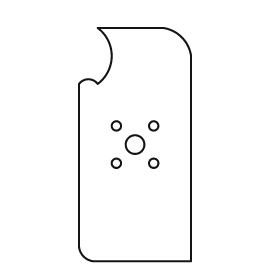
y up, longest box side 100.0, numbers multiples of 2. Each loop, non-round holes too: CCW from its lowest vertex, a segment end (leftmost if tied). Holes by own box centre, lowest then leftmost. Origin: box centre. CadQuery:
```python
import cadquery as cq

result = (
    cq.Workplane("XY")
    .moveTo(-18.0, -50.0)
    .lineTo(24.0, -50.0)
    .lineTo(24.0, 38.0)
    .threePointArc((20.0, 46.0), (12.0, 50.0))
    .lineTo(-16.0, 50.0)
    .threePointArc((-10.0, 38.0), (-16.0, 26.0))
    .threePointArc((-20.0, 28.0), (-24.0, 26.0))
    .lineTo(-24.0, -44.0)
    .threePointArc((-22.0, -48.0), (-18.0, -50.0))
    .close()
    .moveTo(-8.0, -8.0)
    .circle(2.0)
    .moveTo(8.0, -8.0)
    .circle(2.0)
    .moveTo(0.0, 0.0)
    .circle(4.0)
    .moveTo(-8.0, 8.0)
    .circle(2.0)
    .moveTo(8.0, 8.0)
    .circle(2.0)
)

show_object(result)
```